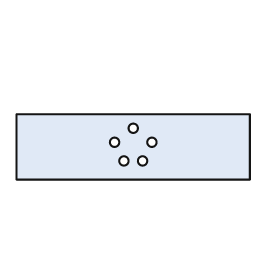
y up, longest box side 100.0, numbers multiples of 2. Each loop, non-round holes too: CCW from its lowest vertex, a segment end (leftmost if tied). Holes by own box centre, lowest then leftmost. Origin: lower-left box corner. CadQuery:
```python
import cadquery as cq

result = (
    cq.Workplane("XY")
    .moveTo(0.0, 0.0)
    .lineTo(100.0, 0.0)
    .lineTo(100.0, 28.0)
    .lineTo(0.0, 28.0)
    .close()
    .moveTo(46.0, 8.0)
    .circle(2.0)
    .moveTo(54.0, 8.0)
    .circle(2.0)
    .moveTo(42.0, 16.0)
    .circle(2.0)
    .moveTo(58.0, 16.0)
    .circle(2.0)
    .moveTo(50.0, 22.0)
    .circle(2.0)
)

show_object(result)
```